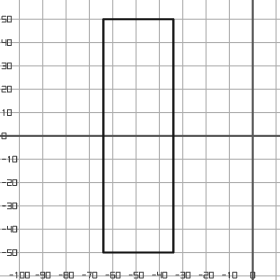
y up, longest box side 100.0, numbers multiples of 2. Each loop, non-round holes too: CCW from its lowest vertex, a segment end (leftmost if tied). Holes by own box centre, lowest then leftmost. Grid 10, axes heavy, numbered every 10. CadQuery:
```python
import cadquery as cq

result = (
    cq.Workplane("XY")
    .moveTo(-64.0, -50.0)
    .lineTo(-34.0, -50.0)
    .lineTo(-34.0, 50.0)
    .lineTo(-64.0, 50.0)
    .close()
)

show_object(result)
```